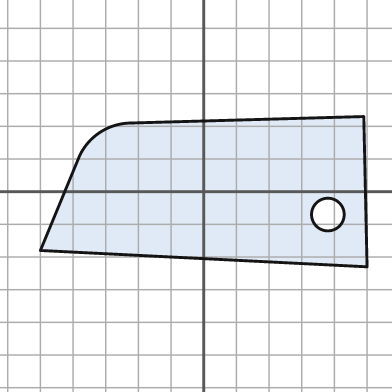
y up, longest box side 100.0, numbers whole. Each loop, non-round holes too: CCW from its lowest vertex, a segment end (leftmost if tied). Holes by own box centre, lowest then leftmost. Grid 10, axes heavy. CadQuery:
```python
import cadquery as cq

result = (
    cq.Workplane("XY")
    .moveTo(50.0, -23.0)
    .lineTo(49.0, 23.0)
    .lineTo(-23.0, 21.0)
    .threePointArc((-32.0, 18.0), (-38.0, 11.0))
    .lineTo(-50.0, -18.0)
    .close()
    .moveTo(38.0, -7.0)
    .circle(5.0)
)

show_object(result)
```